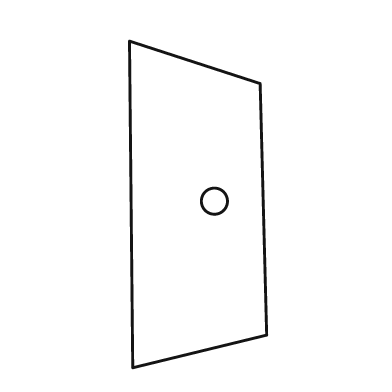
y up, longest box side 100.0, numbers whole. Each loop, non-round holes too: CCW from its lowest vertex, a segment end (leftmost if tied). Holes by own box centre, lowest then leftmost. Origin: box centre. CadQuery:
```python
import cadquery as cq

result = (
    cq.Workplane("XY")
    .moveTo(-20.0, -50.0)
    .lineTo(21.0, -40.0)
    .lineTo(19.0, 37.0)
    .lineTo(-21.0, 50.0)
    .close()
    .moveTo(5.0, 1.0)
    .circle(4.0)
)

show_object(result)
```